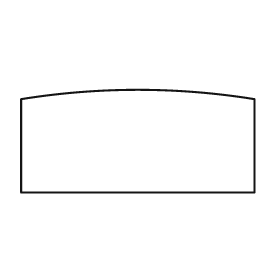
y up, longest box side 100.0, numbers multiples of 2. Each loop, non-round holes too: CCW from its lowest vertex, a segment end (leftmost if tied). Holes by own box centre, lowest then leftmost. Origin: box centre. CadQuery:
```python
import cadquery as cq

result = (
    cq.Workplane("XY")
    .moveTo(-50.0, -22.0)
    .lineTo(50.0, -22.0)
    .lineTo(50.0, 18.0)
    .threePointArc((0.0, 22.0), (-50.0, 18.0))
    .close()
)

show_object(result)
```